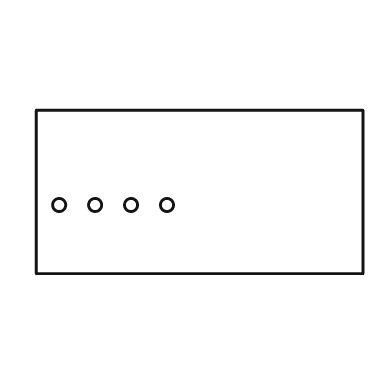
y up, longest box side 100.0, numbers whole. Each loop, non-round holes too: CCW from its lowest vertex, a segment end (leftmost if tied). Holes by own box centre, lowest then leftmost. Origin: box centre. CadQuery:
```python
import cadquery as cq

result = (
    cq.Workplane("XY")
    .moveTo(-50.0, -25.0)
    .lineTo(50.0, -25.0)
    .lineTo(50.0, 25.0)
    .lineTo(-50.0, 25.0)
    .close()
    .moveTo(-43.0, -4.0)
    .circle(2.0)
    .moveTo(-32.0, -4.0)
    .circle(2.0)
    .moveTo(-21.0, -4.0)
    .circle(2.0)
    .moveTo(-10.0, -4.0)
    .circle(2.0)
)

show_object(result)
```